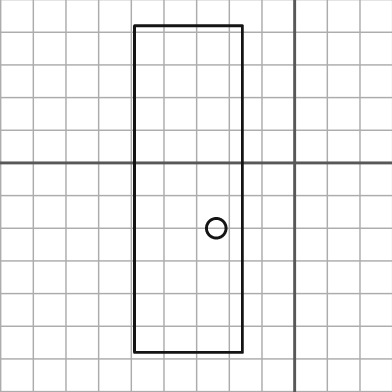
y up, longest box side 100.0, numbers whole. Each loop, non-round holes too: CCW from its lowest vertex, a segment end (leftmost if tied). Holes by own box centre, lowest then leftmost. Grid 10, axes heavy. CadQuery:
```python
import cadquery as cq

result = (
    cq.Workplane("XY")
    .moveTo(-49.0, -58.0)
    .lineTo(-16.0, -58.0)
    .lineTo(-16.0, 42.0)
    .lineTo(-49.0, 42.0)
    .close()
    .moveTo(-24.0, -20.0)
    .circle(3.0)
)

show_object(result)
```